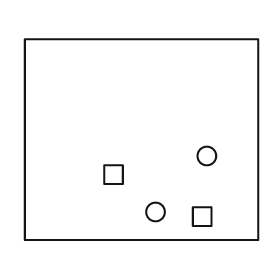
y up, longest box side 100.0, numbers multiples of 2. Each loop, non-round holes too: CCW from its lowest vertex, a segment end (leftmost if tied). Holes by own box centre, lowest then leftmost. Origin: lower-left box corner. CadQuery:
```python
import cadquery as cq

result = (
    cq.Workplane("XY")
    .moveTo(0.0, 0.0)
    .lineTo(100.0, 0.0)
    .lineTo(100.0, 86.0)
    .lineTo(0.0, 86.0)
    .close()
    .moveTo(72.0, 6.0)
    .lineTo(80.0, 6.0)
    .lineTo(80.0, 14.0)
    .lineTo(72.0, 14.0)
    .close()
    .moveTo(56.0, 12.0)
    .circle(4.0)
    .moveTo(34.0, 24.0)
    .lineTo(42.0, 24.0)
    .lineTo(42.0, 32.0)
    .lineTo(34.0, 32.0)
    .close()
    .moveTo(78.0, 36.0)
    .circle(4.0)
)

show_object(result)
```